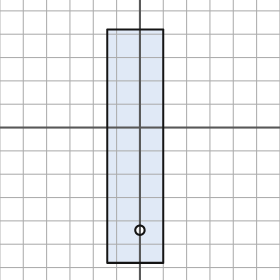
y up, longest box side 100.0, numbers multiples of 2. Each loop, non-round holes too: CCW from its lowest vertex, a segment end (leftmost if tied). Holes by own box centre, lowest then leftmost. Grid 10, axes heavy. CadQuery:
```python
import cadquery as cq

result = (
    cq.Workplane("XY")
    .moveTo(-14.0, -58.0)
    .lineTo(10.0, -58.0)
    .lineTo(10.0, 42.0)
    .lineTo(-14.0, 42.0)
    .close()
    .moveTo(0.0, -44.0)
    .circle(2.0)
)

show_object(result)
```